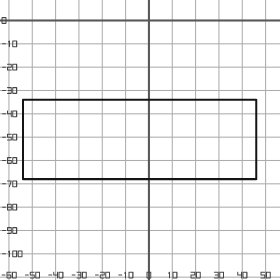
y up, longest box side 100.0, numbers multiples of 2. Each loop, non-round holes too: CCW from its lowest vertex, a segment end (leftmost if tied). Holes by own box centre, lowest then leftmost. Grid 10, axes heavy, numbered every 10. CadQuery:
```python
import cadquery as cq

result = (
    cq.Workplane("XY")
    .moveTo(-54.0, -68.0)
    .lineTo(46.0, -68.0)
    .lineTo(46.0, -34.0)
    .lineTo(-54.0, -34.0)
    .close()
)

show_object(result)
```